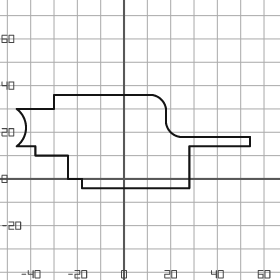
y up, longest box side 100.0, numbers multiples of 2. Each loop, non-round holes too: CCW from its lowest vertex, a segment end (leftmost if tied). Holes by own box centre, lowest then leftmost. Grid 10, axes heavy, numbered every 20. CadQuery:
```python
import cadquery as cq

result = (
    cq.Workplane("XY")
    .moveTo(-18.0, -4.0)
    .lineTo(28.0, -4.0)
    .lineTo(28.0, 14.0)
    .lineTo(54.0, 14.0)
    .lineTo(54.0, 18.0)
    .lineTo(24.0, 18.0)
    .threePointArc((20.0, 20.0), (18.0, 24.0))
    .lineTo(18.0, 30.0)
    .threePointArc((16.0, 34.0), (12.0, 36.0))
    .lineTo(-30.0, 36.0)
    .lineTo(-30.0, 30.0)
    .lineTo(-46.0, 30.0)
    .threePointArc((-42.0, 22.0), (-46.0, 14.0))
    .lineTo(-38.0, 14.0)
    .lineTo(-38.0, 10.0)
    .lineTo(-24.0, 10.0)
    .lineTo(-24.0, 0.0)
    .lineTo(-18.0, 0.0)
    .close()
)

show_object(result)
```